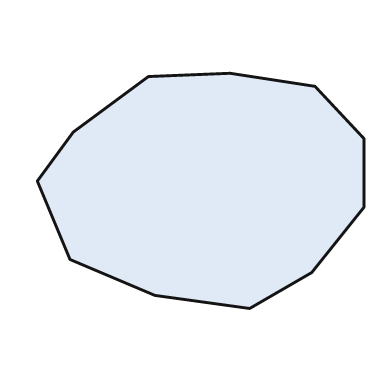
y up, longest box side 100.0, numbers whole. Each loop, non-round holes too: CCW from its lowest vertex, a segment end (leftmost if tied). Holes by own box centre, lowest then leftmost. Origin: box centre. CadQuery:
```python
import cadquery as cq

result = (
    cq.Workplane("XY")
    .moveTo(15.0, -36.0)
    .lineTo(34.0, -25.0)
    .lineTo(50.0, -5.0)
    .lineTo(50.0, 16.0)
    .lineTo(35.0, 32.0)
    .lineTo(9.0, 36.0)
    .lineTo(-16.0, 35.0)
    .lineTo(-39.0, 18.0)
    .lineTo(-50.0, 3.0)
    .lineTo(-40.0, -21.0)
    .lineTo(-14.0, -32.0)
    .close()
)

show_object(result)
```